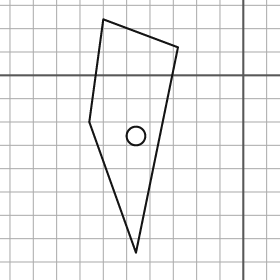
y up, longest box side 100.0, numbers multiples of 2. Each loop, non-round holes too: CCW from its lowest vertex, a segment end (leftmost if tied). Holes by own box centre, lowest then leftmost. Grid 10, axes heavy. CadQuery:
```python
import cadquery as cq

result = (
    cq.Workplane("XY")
    .moveTo(-46.0, -76.0)
    .lineTo(-28.0, 12.0)
    .lineTo(-60.0, 24.0)
    .lineTo(-66.0, -20.0)
    .close()
    .moveTo(-46.0, -26.0)
    .circle(4.0)
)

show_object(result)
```